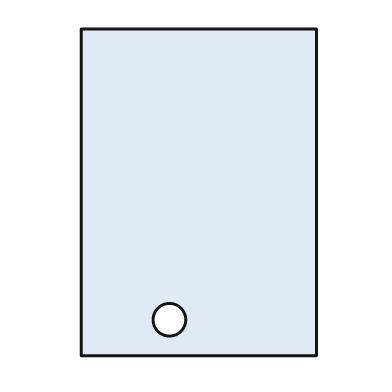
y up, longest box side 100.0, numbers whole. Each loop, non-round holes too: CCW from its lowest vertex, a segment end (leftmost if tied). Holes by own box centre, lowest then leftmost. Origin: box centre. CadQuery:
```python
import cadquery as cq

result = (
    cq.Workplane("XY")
    .moveTo(-36.0, -50.0)
    .lineTo(36.0, -50.0)
    .lineTo(36.0, 50.0)
    .lineTo(-36.0, 50.0)
    .close()
    .moveTo(-9.0, -39.0)
    .circle(5.0)
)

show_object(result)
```